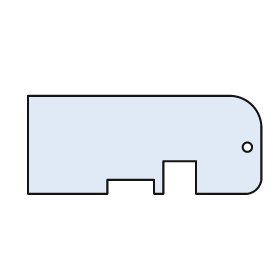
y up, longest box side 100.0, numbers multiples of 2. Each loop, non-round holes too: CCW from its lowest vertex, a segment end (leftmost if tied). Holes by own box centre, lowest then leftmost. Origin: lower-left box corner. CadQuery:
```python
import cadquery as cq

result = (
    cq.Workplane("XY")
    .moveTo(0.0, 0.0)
    .lineTo(34.0, 0.0)
    .lineTo(34.0, 6.0)
    .lineTo(54.0, 6.0)
    .lineTo(54.0, 0.0)
    .lineTo(58.0, 0.0)
    .lineTo(58.0, 14.0)
    .lineTo(72.0, 14.0)
    .lineTo(72.0, 0.0)
    .lineTo(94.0, 0.0)
    .threePointArc((98.0, 2.0), (100.0, 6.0))
    .lineTo(100.0, 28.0)
    .threePointArc((96.0, 38.0), (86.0, 42.0))
    .lineTo(0.0, 42.0)
    .close()
    .moveTo(94.0, 20.0)
    .circle(2.0)
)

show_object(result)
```